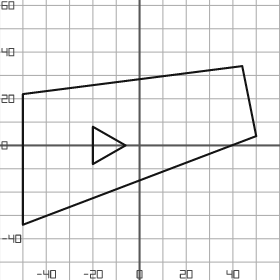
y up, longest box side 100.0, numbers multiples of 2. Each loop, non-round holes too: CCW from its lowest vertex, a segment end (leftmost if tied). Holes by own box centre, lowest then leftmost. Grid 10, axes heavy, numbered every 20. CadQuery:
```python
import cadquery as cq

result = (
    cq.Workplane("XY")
    .moveTo(-50.0, -34.0)
    .lineTo(50.0, 4.0)
    .lineTo(44.0, 34.0)
    .lineTo(-50.0, 22.0)
    .close()
    .moveTo(-20.0, -8.0)
    .lineTo(-6.0, 0.0)
    .lineTo(-20.0, 8.0)
    .close()
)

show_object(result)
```